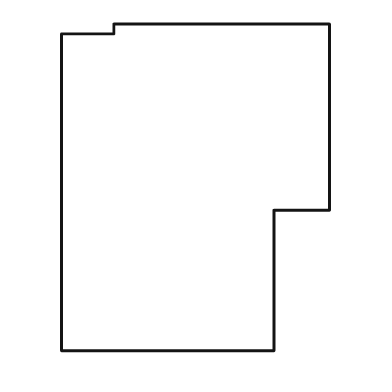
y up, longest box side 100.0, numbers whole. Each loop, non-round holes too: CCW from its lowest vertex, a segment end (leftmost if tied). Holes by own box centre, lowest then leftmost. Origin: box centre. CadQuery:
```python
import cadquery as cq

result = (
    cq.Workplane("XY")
    .moveTo(-41.0, -50.0)
    .lineTo(24.0, -50.0)
    .lineTo(24.0, -7.0)
    .lineTo(41.0, -7.0)
    .lineTo(41.0, 50.0)
    .lineTo(-25.0, 50.0)
    .lineTo(-25.0, 47.0)
    .lineTo(-41.0, 47.0)
    .close()
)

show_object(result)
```